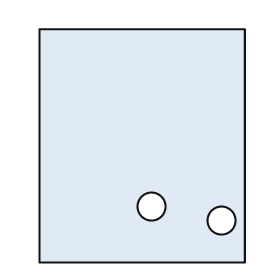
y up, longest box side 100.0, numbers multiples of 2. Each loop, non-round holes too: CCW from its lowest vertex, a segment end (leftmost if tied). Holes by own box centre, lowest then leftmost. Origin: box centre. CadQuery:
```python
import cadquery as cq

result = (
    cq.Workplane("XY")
    .moveTo(-44.0, -50.0)
    .lineTo(44.0, -50.0)
    .lineTo(44.0, 50.0)
    .lineTo(-44.0, 50.0)
    .close()
    .moveTo(34.0, -32.0)
    .circle(6.0)
    .moveTo(4.0, -26.0)
    .circle(6.0)
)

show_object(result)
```